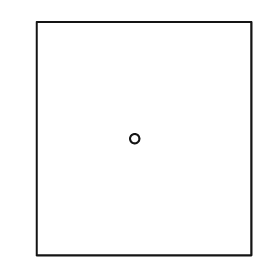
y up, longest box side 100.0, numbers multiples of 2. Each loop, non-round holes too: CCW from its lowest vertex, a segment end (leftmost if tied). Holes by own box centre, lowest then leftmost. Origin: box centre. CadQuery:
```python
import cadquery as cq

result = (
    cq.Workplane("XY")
    .moveTo(-46.0, -50.0)
    .lineTo(46.0, -50.0)
    .lineTo(46.0, 50.0)
    .lineTo(-46.0, 50.0)
    .close()
    .moveTo(-4.0, 0.0)
    .circle(2.0)
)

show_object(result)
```